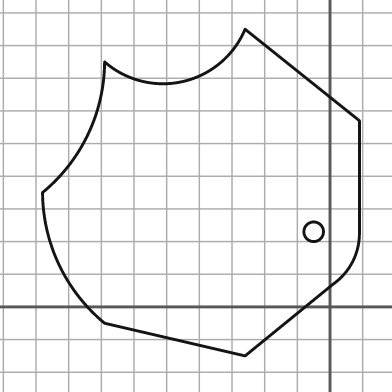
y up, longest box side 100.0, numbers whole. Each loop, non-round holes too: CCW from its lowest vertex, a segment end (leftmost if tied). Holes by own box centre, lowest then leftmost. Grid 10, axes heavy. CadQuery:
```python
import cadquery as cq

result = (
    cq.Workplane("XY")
    .moveTo(-26.0, -15.0)
    .lineTo(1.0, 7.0)
    .threePointArc((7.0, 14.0), (9.0, 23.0))
    .lineTo(9.0, 57.0)
    .lineTo(-26.0, 85.0)
    .threePointArc((-45.0, 69.0), (-69.0, 75.0))
    .threePointArc((-74.0, 53.0), (-88.0, 35.0))
    .threePointArc((-83.0, 13.0), (-69.0, -5.0))
    .close()
    .moveTo(-5.0, 23.0)
    .circle(3.0)
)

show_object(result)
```